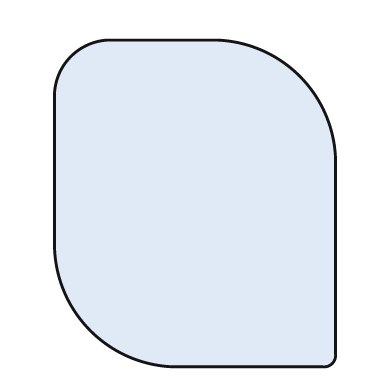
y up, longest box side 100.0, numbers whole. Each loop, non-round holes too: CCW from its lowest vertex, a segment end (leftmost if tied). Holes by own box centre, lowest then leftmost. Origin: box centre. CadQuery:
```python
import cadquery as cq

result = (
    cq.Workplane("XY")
    .moveTo(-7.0, -50.0)
    .lineTo(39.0, -50.0)
    .threePointArc((42.0, -49.0), (43.0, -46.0))
    .lineTo(43.0, 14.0)
    .threePointArc((32.0, 39.0), (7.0, 50.0))
    .lineTo(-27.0, 50.0)
    .threePointArc((-38.0, 45.0), (-43.0, 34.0))
    .lineTo(-43.0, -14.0)
    .threePointArc((-32.0, -39.0), (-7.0, -50.0))
    .close()
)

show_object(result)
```